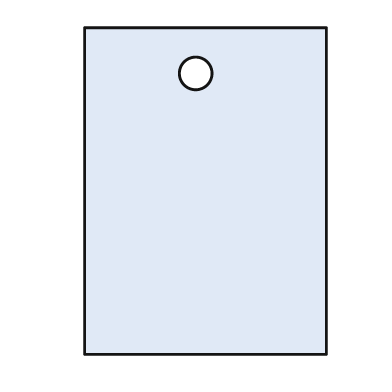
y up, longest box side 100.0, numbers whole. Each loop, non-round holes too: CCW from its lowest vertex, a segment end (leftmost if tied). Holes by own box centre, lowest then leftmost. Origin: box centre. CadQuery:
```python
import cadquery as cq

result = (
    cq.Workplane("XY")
    .moveTo(-37.0, -50.0)
    .lineTo(37.0, -50.0)
    .lineTo(37.0, 50.0)
    .lineTo(-37.0, 50.0)
    .close()
    .moveTo(-3.0, 36.0)
    .circle(5.0)
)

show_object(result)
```